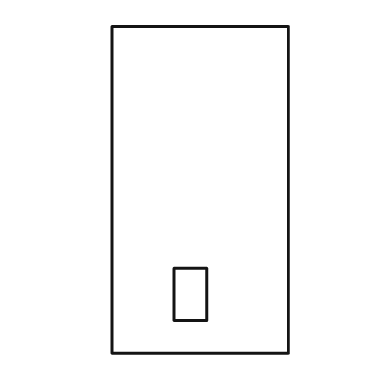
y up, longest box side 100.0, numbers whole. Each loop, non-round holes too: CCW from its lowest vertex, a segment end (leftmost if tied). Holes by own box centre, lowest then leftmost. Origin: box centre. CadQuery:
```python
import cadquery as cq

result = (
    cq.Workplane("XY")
    .moveTo(-27.0, -50.0)
    .lineTo(27.0, -50.0)
    .lineTo(27.0, 50.0)
    .lineTo(-27.0, 50.0)
    .close()
    .moveTo(-8.0, -40.0)
    .lineTo(2.0, -40.0)
    .lineTo(2.0, -24.0)
    .lineTo(-8.0, -24.0)
    .close()
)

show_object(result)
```